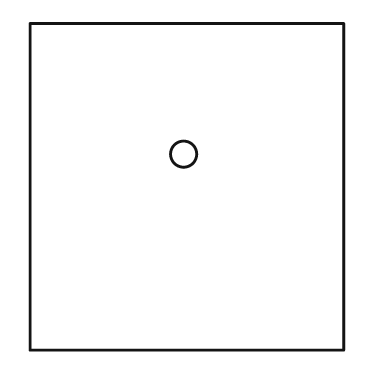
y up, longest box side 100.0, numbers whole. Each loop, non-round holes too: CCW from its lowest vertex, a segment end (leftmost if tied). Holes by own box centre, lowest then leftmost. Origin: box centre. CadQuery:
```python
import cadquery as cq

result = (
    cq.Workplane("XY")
    .moveTo(-48.0, -50.0)
    .lineTo(48.0, -50.0)
    .lineTo(48.0, 50.0)
    .lineTo(-48.0, 50.0)
    .close()
    .moveTo(-1.0, 10.0)
    .circle(4.0)
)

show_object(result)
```